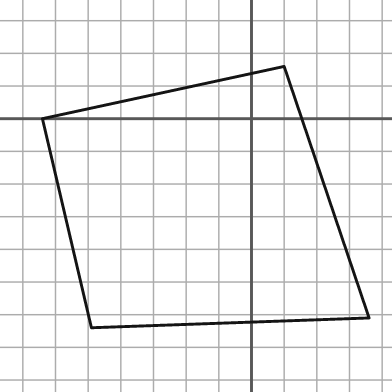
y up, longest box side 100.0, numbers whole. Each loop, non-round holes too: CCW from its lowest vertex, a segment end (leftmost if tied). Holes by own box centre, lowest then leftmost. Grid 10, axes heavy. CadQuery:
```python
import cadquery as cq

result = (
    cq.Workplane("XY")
    .moveTo(-49.0, -64.0)
    .lineTo(36.0, -61.0)
    .lineTo(10.0, 16.0)
    .lineTo(-64.0, 0.0)
    .close()
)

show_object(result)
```